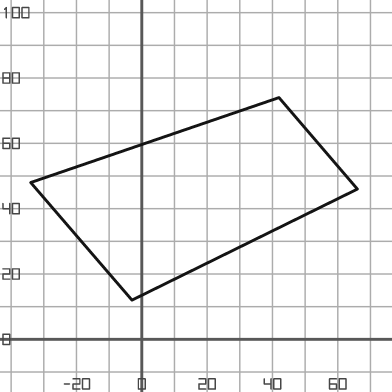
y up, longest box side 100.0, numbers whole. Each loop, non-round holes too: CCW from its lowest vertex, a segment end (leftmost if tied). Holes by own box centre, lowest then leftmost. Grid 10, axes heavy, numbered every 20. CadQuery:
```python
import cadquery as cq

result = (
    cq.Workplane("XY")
    .moveTo(-3.0, 12.0)
    .lineTo(66.0, 46.0)
    .lineTo(42.0, 74.0)
    .lineTo(-34.0, 48.0)
    .close()
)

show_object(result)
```